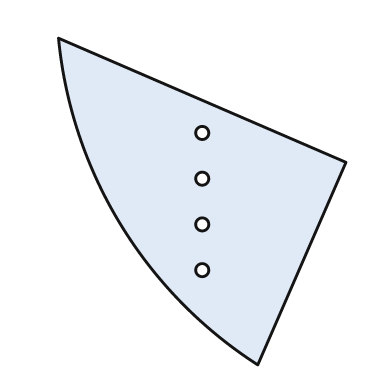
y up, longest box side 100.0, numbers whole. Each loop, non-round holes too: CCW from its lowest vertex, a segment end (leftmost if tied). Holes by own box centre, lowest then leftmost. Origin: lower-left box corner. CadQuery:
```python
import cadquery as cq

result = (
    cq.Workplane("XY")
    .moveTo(61.0, 0.0)
    .lineTo(88.0, 62.0)
    .lineTo(0.0, 100.0)
    .threePointArc((19.0, 43.0), (61.0, 0.0))
    .close()
    .moveTo(44.0, 29.0)
    .circle(2.0)
    .moveTo(44.0, 43.0)
    .circle(2.0)
    .moveTo(44.0, 57.0)
    .circle(2.0)
    .moveTo(44.0, 71.0)
    .circle(2.0)
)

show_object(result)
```